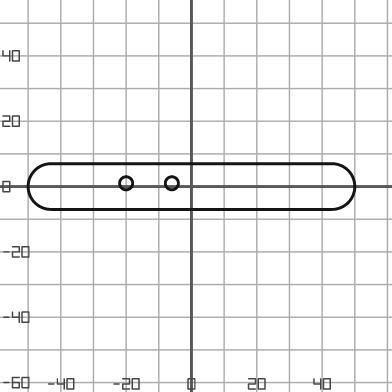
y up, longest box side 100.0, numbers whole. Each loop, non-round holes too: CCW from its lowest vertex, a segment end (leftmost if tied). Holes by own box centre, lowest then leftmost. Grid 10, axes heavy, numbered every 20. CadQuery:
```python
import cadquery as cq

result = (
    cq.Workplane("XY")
    .moveTo(-43.0, -7.0)
    .lineTo(43.0, -7.0)
    .threePointArc((50.0, 0.0), (43.0, 7.0))
    .lineTo(-43.0, 7.0)
    .threePointArc((-50.0, 0.0), (-43.0, -7.0))
    .close()
    .moveTo(-20.0, 1.0)
    .circle(2.0)
    .moveTo(-6.0, 1.0)
    .circle(2.0)
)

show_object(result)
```